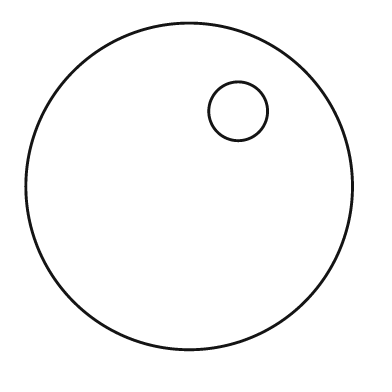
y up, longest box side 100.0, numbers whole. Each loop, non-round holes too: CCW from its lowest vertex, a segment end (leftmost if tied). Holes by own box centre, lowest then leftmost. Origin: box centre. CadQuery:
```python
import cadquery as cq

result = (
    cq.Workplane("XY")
    .moveTo(0.0, 0.0)
    .circle(50.0)
    .moveTo(15.0, 23.0)
    .circle(9.0)
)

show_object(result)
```